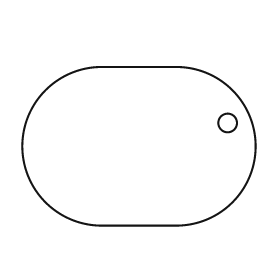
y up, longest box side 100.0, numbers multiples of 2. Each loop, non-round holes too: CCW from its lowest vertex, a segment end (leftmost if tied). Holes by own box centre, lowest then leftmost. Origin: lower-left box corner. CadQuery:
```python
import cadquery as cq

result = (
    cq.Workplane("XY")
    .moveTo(34.0, 0.0)
    .lineTo(66.0, 0.0)
    .threePointArc((100.0, 34.0), (66.0, 68.0))
    .lineTo(34.0, 68.0)
    .threePointArc((0.0, 34.0), (34.0, 0.0))
    .close()
    .moveTo(88.0, 44.0)
    .circle(4.0)
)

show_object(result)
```